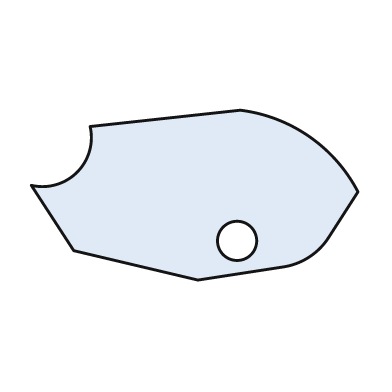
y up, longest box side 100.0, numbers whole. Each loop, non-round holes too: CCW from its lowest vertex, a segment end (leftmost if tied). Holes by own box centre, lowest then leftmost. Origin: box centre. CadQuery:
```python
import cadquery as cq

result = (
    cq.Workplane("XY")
    .moveTo(1.0, -26.0)
    .lineTo(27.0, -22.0)
    .threePointArc((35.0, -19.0), (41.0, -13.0))
    .lineTo(50.0, 1.0)
    .threePointArc((35.0, 18.0), (14.0, 26.0))
    .lineTo(-32.0, 21.0)
    .threePointArc((-36.0, 7.0), (-50.0, 3.0))
    .lineTo(-37.0, -17.0)
    .close()
    .moveTo(13.0, -14.0)
    .circle(6.0)
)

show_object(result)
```